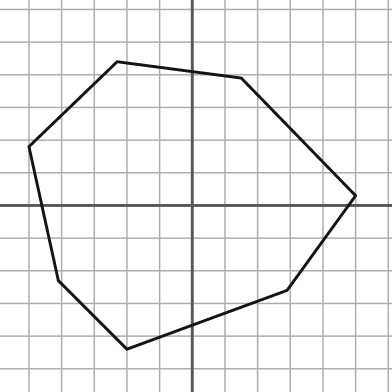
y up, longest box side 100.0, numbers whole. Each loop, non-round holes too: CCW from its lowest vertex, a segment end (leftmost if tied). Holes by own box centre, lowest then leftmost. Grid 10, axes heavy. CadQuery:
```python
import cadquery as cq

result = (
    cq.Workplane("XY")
    .moveTo(-20.0, -44.0)
    .lineTo(29.0, -26.0)
    .lineTo(50.0, 3.0)
    .lineTo(15.0, 39.0)
    .lineTo(-23.0, 44.0)
    .lineTo(-50.0, 18.0)
    .lineTo(-41.0, -23.0)
    .close()
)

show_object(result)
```